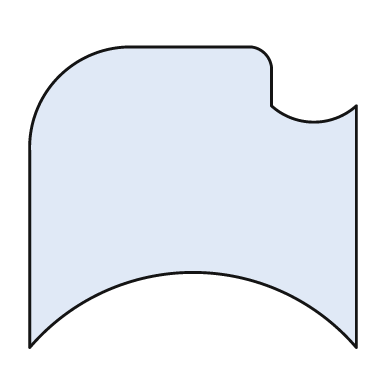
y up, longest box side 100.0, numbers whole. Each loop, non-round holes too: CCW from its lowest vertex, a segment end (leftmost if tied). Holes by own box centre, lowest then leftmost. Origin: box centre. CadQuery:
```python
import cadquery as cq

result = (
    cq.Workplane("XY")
    .moveTo(-50.0, -46.0)
    .threePointArc((0.0, -23.0), (50.0, -46.0))
    .lineTo(50.0, 28.0)
    .threePointArc((37.0, 23.0), (24.0, 28.0))
    .lineTo(24.0, 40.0)
    .threePointArc((22.0, 44.0), (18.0, 46.0))
    .lineTo(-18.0, 46.0)
    .threePointArc((-41.0, 37.0), (-50.0, 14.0))
    .close()
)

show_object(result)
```